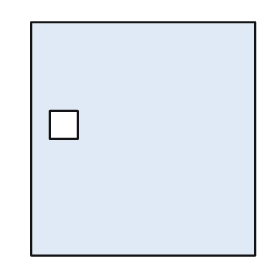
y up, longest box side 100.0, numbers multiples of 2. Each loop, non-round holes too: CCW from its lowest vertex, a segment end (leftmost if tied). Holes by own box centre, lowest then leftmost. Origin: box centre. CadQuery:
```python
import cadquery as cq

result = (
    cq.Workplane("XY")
    .moveTo(-48.0, -50.0)
    .lineTo(48.0, -50.0)
    .lineTo(48.0, 50.0)
    .lineTo(-48.0, 50.0)
    .close()
    .moveTo(-40.0, 0.0)
    .lineTo(-28.0, 0.0)
    .lineTo(-28.0, 12.0)
    .lineTo(-40.0, 12.0)
    .close()
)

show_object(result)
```